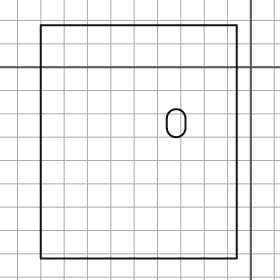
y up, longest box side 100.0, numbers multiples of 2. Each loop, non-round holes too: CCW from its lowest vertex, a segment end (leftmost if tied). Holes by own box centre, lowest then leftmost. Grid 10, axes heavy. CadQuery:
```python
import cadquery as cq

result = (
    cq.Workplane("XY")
    .moveTo(-90.0, -82.0)
    .lineTo(-6.0, -82.0)
    .lineTo(-6.0, 18.0)
    .lineTo(-90.0, 18.0)
    .close()
    .moveTo(-36.0, -26.0)
    .threePointArc((-32.0, -30.0), (-28.0, -26.0))
    .lineTo(-28.0, -22.0)
    .threePointArc((-32.0, -18.0), (-36.0, -22.0))
    .close()
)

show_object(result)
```